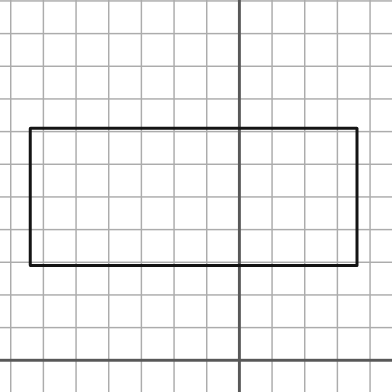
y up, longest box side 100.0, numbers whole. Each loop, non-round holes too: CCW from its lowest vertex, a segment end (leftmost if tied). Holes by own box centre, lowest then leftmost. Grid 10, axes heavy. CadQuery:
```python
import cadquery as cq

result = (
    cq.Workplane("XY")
    .moveTo(-64.0, 29.0)
    .lineTo(36.0, 29.0)
    .lineTo(36.0, 71.0)
    .lineTo(-64.0, 71.0)
    .close()
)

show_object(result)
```